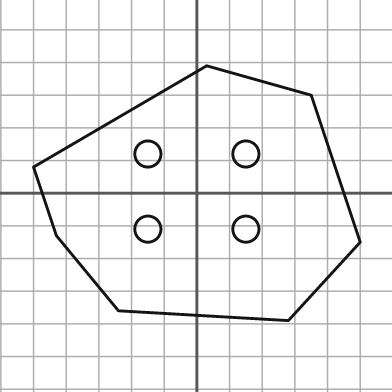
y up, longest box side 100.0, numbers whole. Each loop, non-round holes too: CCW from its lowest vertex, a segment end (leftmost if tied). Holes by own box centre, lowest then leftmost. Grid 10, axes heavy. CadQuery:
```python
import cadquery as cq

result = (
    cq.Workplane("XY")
    .moveTo(28.0, -39.0)
    .lineTo(50.0, -15.0)
    .lineTo(35.0, 30.0)
    .lineTo(3.0, 39.0)
    .lineTo(-50.0, 8.0)
    .lineTo(-43.0, -13.0)
    .lineTo(-24.0, -36.0)
    .close()
    .moveTo(-15.0, -11.0)
    .circle(4.0)
    .moveTo(15.0, -11.0)
    .circle(4.0)
    .moveTo(-15.0, 12.0)
    .circle(4.0)
    .moveTo(15.0, 12.0)
    .circle(4.0)
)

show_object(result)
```